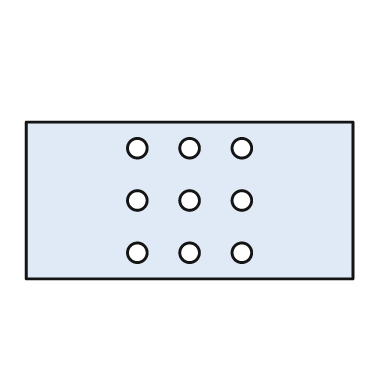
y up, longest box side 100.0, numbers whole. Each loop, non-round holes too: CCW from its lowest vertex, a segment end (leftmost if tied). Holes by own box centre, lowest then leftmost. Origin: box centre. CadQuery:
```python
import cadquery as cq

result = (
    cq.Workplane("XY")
    .moveTo(-50.0, -24.0)
    .lineTo(50.0, -24.0)
    .lineTo(50.0, 24.0)
    .lineTo(-50.0, 24.0)
    .close()
    .moveTo(-16.0, -16.0)
    .circle(3.0)
    .moveTo(0.0, -16.0)
    .circle(3.0)
    .moveTo(16.0, -16.0)
    .circle(3.0)
    .moveTo(-16.0, 0.0)
    .circle(3.0)
    .moveTo(0.0, 0.0)
    .circle(3.0)
    .moveTo(16.0, 0.0)
    .circle(3.0)
    .moveTo(-16.0, 16.0)
    .circle(3.0)
    .moveTo(0.0, 16.0)
    .circle(3.0)
    .moveTo(16.0, 16.0)
    .circle(3.0)
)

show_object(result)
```